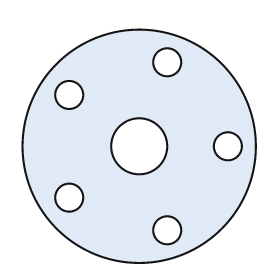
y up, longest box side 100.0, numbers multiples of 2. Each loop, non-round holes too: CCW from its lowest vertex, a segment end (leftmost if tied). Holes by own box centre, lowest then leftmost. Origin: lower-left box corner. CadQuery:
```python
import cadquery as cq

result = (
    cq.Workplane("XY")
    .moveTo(50.0, 50.0)
    .circle(50.0)
    .moveTo(62.0, 14.0)
    .circle(6.0)
    .moveTo(20.0, 28.0)
    .circle(6.0)
    .moveTo(50.0, 50.0)
    .circle(12.0)
    .moveTo(88.0, 50.0)
    .circle(6.0)
    .moveTo(20.0, 72.0)
    .circle(6.0)
    .moveTo(62.0, 86.0)
    .circle(6.0)
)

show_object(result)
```